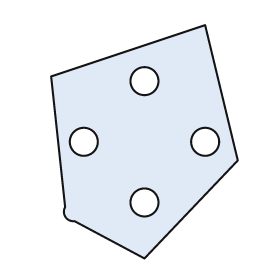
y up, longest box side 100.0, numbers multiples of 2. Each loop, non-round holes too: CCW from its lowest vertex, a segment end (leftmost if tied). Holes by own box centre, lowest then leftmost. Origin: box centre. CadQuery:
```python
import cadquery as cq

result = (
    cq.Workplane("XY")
    .moveTo(0.0, -50.0)
    .lineTo(40.0, -8.0)
    .lineTo(26.0, 50.0)
    .lineTo(-40.0, 28.0)
    .lineTo(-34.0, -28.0)
    .threePointArc((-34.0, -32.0), (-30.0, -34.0))
    .close()
    .moveTo(0.0, -26.0)
    .circle(6.0)
    .moveTo(-26.0, 0.0)
    .circle(6.0)
    .moveTo(26.0, 0.0)
    .circle(6.0)
    .moveTo(0.0, 26.0)
    .circle(6.0)
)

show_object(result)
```